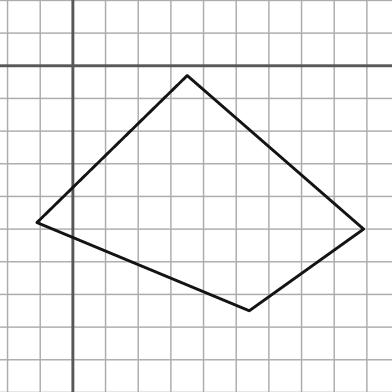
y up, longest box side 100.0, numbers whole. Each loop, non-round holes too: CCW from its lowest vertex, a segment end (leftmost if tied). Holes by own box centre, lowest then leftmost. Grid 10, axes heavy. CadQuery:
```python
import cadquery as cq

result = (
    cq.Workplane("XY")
    .moveTo(54.0, -75.0)
    .lineTo(89.0, -50.0)
    .lineTo(35.0, -3.0)
    .lineTo(-11.0, -48.0)
    .close()
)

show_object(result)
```